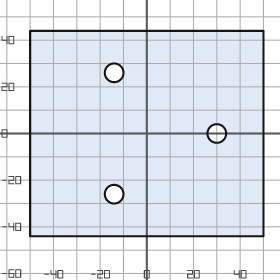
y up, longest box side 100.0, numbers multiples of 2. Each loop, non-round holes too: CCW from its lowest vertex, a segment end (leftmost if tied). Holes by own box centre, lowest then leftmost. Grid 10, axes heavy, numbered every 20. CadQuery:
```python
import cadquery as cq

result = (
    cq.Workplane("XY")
    .moveTo(-50.0, -44.0)
    .lineTo(50.0, -44.0)
    .lineTo(50.0, 44.0)
    .lineTo(-50.0, 44.0)
    .close()
    .moveTo(-14.0, -26.0)
    .circle(4.0)
    .moveTo(30.0, 0.0)
    .circle(4.0)
    .moveTo(-14.0, 26.0)
    .circle(4.0)
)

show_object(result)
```